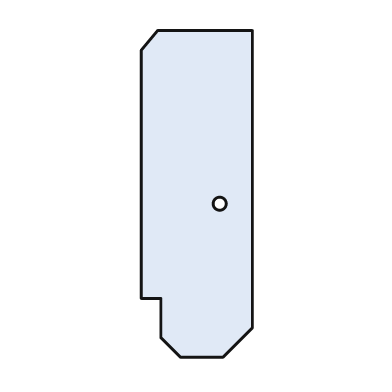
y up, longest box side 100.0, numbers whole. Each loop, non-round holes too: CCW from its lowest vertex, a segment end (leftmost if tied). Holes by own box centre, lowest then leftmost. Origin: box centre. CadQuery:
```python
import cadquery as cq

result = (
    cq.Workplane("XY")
    .moveTo(-5.0, -50.0)
    .lineTo(8.0, -50.0)
    .lineTo(17.0, -41.0)
    .lineTo(17.0, 50.0)
    .lineTo(-12.0, 50.0)
    .lineTo(-17.0, 44.0)
    .lineTo(-17.0, -32.0)
    .lineTo(-11.0, -32.0)
    .lineTo(-11.0, -44.0)
    .close()
    .moveTo(7.0, -3.0)
    .circle(2.0)
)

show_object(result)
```